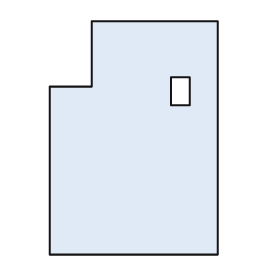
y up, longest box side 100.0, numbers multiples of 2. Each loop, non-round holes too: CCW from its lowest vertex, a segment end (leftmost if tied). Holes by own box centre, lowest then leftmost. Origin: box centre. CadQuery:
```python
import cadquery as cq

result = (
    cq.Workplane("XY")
    .moveTo(-36.0, -50.0)
    .lineTo(36.0, -50.0)
    .lineTo(36.0, 50.0)
    .lineTo(-18.0, 50.0)
    .lineTo(-18.0, 22.0)
    .lineTo(-36.0, 22.0)
    .close()
    .moveTo(16.0, 14.0)
    .lineTo(24.0, 14.0)
    .lineTo(24.0, 26.0)
    .lineTo(16.0, 26.0)
    .close()
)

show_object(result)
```